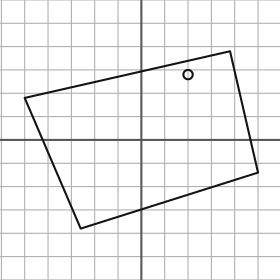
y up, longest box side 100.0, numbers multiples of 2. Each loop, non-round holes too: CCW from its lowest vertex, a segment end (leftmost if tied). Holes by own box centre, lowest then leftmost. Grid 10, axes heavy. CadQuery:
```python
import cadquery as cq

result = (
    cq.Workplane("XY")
    .moveTo(-26.0, -38.0)
    .lineTo(50.0, -14.0)
    .lineTo(38.0, 38.0)
    .lineTo(-50.0, 18.0)
    .close()
    .moveTo(20.0, 28.0)
    .circle(2.0)
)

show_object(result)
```